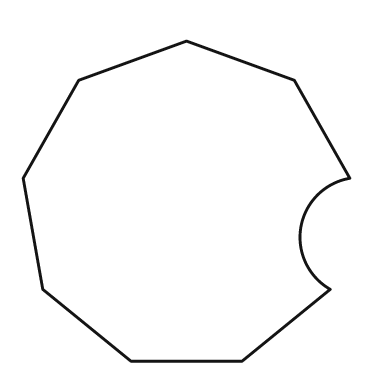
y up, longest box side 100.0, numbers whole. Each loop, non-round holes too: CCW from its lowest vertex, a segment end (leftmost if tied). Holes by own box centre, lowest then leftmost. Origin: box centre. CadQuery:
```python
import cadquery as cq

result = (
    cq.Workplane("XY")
    .moveTo(-17.0, -49.0)
    .lineTo(17.0, -49.0)
    .lineTo(44.0, -27.0)
    .threePointArc((35.0, -8.0), (50.0, 7.0))
    .lineTo(33.0, 37.0)
    .lineTo(0.0, 49.0)
    .lineTo(-33.0, 37.0)
    .lineTo(-50.0, 7.0)
    .lineTo(-44.0, -27.0)
    .close()
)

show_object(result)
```